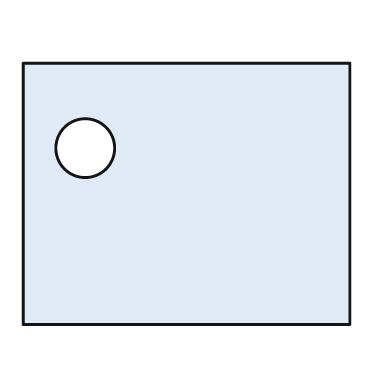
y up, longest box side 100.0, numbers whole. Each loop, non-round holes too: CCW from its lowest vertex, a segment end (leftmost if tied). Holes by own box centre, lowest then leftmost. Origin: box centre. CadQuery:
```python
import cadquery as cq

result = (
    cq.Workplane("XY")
    .moveTo(-50.0, -40.0)
    .lineTo(50.0, -40.0)
    .lineTo(50.0, 40.0)
    .lineTo(-50.0, 40.0)
    .close()
    .moveTo(-31.0, 14.0)
    .circle(9.0)
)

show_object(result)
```